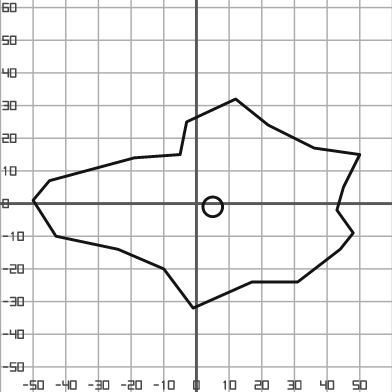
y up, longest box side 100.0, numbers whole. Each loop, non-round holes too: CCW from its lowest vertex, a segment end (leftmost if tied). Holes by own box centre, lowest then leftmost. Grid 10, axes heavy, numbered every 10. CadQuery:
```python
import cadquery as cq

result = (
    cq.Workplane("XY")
    .moveTo(-1.0, -32.0)
    .lineTo(17.0, -24.0)
    .lineTo(31.0, -24.0)
    .lineTo(44.0, -14.0)
    .lineTo(48.0, -9.0)
    .lineTo(43.0, -2.0)
    .lineTo(45.0, 5.0)
    .lineTo(50.0, 15.0)
    .lineTo(36.0, 17.0)
    .lineTo(22.0, 24.0)
    .lineTo(12.0, 32.0)
    .lineTo(-3.0, 25.0)
    .lineTo(-5.0, 15.0)
    .lineTo(-19.0, 14.0)
    .lineTo(-45.0, 7.0)
    .lineTo(-50.0, 1.0)
    .lineTo(-43.0, -10.0)
    .lineTo(-24.0, -14.0)
    .lineTo(-10.0, -20.0)
    .close()
    .moveTo(5.0, -1.0)
    .circle(3.0)
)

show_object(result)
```